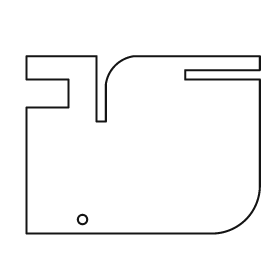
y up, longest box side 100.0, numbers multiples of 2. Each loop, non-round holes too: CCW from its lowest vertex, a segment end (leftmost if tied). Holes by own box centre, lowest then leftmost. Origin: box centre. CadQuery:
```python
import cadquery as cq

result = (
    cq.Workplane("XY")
    .moveTo(-50.0, -38.0)
    .lineTo(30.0, -38.0)
    .threePointArc((44.0, -32.0), (50.0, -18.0))
    .lineTo(50.0, 28.0)
    .lineTo(18.0, 28.0)
    .lineTo(18.0, 32.0)
    .lineTo(50.0, 32.0)
    .lineTo(50.0, 38.0)
    .lineTo(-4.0, 38.0)
    .threePointArc((-12.0, 34.0), (-16.0, 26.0))
    .lineTo(-16.0, 10.0)
    .lineTo(-20.0, 10.0)
    .lineTo(-20.0, 38.0)
    .lineTo(-50.0, 38.0)
    .lineTo(-50.0, 28.0)
    .lineTo(-32.0, 28.0)
    .lineTo(-32.0, 16.0)
    .lineTo(-50.0, 16.0)
    .close()
    .moveTo(-26.0, -32.0)
    .circle(2.0)
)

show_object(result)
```